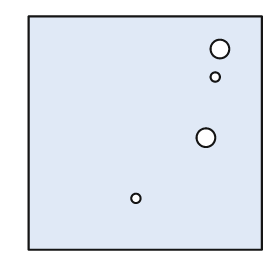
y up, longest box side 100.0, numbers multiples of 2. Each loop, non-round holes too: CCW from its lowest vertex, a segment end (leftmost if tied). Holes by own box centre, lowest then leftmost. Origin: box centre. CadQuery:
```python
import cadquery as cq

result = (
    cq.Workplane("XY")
    .moveTo(-50.0, -50.0)
    .lineTo(50.0, -50.0)
    .lineTo(50.0, 50.0)
    .lineTo(-50.0, 50.0)
    .close()
    .moveTo(-4.0, -28.0)
    .circle(2.0)
    .moveTo(26.0, -2.0)
    .circle(4.0)
    .moveTo(30.0, 24.0)
    .circle(2.0)
    .moveTo(32.0, 36.0)
    .circle(4.0)
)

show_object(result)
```